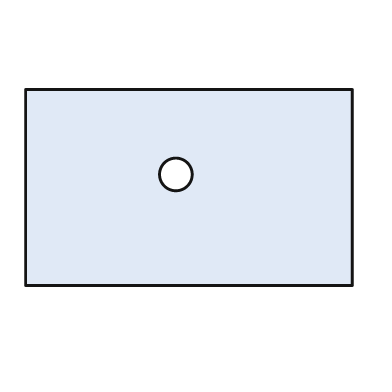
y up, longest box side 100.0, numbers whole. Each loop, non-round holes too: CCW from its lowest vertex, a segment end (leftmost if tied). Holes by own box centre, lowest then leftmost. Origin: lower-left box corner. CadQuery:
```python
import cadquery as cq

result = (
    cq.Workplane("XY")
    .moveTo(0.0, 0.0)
    .lineTo(100.0, 0.0)
    .lineTo(100.0, 60.0)
    .lineTo(0.0, 60.0)
    .close()
    .moveTo(46.0, 34.0)
    .circle(5.0)
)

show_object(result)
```